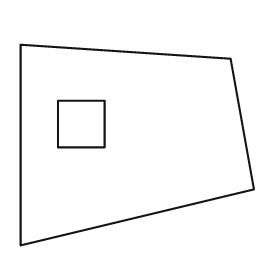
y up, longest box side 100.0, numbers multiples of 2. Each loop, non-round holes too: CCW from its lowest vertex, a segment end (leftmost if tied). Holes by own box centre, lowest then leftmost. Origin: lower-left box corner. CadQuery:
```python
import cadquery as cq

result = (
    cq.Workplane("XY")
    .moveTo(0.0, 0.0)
    .lineTo(100.0, 24.0)
    .lineTo(90.0, 80.0)
    .lineTo(0.0, 86.0)
    .close()
    .moveTo(16.0, 42.0)
    .lineTo(36.0, 42.0)
    .lineTo(36.0, 62.0)
    .lineTo(16.0, 62.0)
    .close()
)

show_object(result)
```